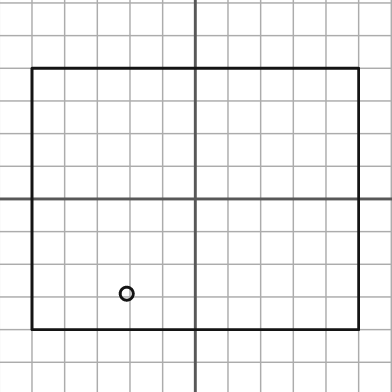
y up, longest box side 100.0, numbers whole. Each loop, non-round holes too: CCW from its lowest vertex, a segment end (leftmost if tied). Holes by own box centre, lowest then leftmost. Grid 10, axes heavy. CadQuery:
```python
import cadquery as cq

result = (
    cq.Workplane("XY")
    .moveTo(-50.0, -40.0)
    .lineTo(50.0, -40.0)
    .lineTo(50.0, 40.0)
    .lineTo(-50.0, 40.0)
    .close()
    .moveTo(-21.0, -29.0)
    .circle(2.0)
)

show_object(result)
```